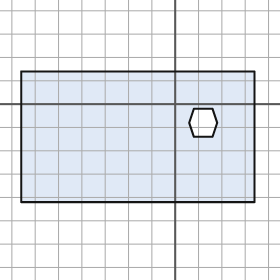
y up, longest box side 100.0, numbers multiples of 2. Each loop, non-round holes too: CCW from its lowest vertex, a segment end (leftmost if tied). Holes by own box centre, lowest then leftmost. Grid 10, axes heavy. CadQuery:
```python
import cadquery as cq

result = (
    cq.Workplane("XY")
    .moveTo(-66.0, -42.0)
    .lineTo(34.0, -42.0)
    .lineTo(34.0, 14.0)
    .lineTo(-66.0, 14.0)
    .close()
    .moveTo(8.0, -14.0)
    .lineTo(16.0, -14.0)
    .lineTo(18.0, -8.0)
    .lineTo(16.0, -2.0)
    .lineTo(8.0, -2.0)
    .lineTo(6.0, -8.0)
    .close()
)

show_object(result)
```